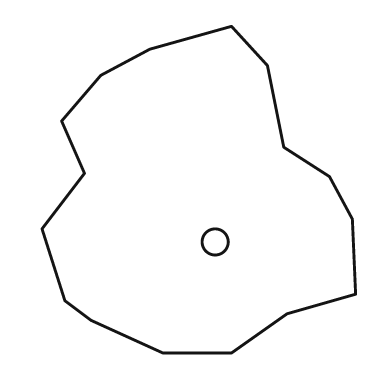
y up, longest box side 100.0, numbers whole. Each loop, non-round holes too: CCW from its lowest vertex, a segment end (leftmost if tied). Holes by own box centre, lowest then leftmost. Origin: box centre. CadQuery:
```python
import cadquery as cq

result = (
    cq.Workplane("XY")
    .moveTo(-11.0, -50.0)
    .lineTo(10.0, -50.0)
    .lineTo(27.0, -38.0)
    .lineTo(48.0, -32.0)
    .lineTo(47.0, -9.0)
    .lineTo(40.0, 4.0)
    .lineTo(26.0, 13.0)
    .lineTo(21.0, 38.0)
    .lineTo(10.0, 50.0)
    .lineTo(-15.0, 43.0)
    .lineTo(-30.0, 35.0)
    .lineTo(-42.0, 21.0)
    .lineTo(-35.0, 5.0)
    .lineTo(-48.0, -12.0)
    .lineTo(-41.0, -34.0)
    .lineTo(-33.0, -40.0)
    .close()
    .moveTo(5.0, -16.0)
    .circle(4.0)
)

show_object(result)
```